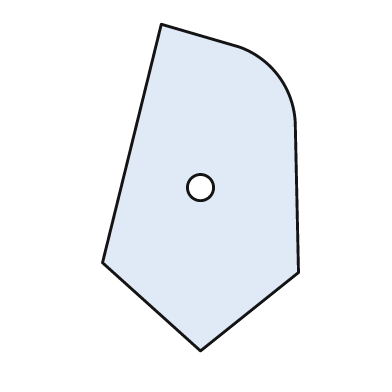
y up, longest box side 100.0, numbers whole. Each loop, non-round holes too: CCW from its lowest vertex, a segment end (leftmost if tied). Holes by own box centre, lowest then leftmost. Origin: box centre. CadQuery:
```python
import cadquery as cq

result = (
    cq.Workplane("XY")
    .moveTo(0.0, -50.0)
    .lineTo(30.0, -26.0)
    .lineTo(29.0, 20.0)
    .threePointArc((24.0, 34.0), (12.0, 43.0))
    .lineTo(-12.0, 50.0)
    .lineTo(-30.0, -23.0)
    .close()
    .moveTo(0.0, 0.0)
    .circle(4.0)
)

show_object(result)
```